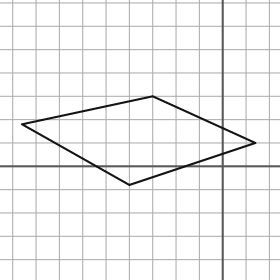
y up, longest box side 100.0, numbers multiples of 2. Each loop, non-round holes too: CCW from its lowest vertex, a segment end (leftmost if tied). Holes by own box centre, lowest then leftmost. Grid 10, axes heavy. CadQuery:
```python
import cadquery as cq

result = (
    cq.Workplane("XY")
    .moveTo(-40.0, -8.0)
    .lineTo(14.0, 10.0)
    .lineTo(-30.0, 30.0)
    .lineTo(-86.0, 18.0)
    .close()
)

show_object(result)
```